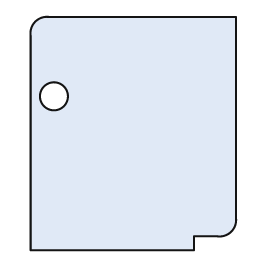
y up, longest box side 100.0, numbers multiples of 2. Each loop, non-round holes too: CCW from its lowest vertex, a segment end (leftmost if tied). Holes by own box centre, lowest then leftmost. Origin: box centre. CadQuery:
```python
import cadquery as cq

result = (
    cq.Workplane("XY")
    .moveTo(-44.0, -50.0)
    .lineTo(26.0, -50.0)
    .lineTo(26.0, -44.0)
    .lineTo(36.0, -44.0)
    .threePointArc((42.0, -42.0), (44.0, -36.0))
    .lineTo(44.0, 50.0)
    .lineTo(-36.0, 50.0)
    .threePointArc((-42.0, 48.0), (-44.0, 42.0))
    .close()
    .moveTo(-34.0, 16.0)
    .circle(6.0)
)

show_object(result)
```